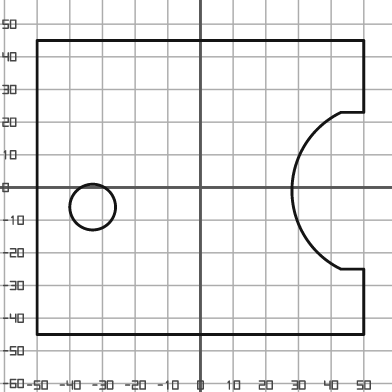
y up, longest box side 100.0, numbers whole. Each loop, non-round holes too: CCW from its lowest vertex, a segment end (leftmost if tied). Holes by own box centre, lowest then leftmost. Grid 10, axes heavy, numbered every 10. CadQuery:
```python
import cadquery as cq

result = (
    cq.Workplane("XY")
    .moveTo(-50.0, -45.0)
    .lineTo(50.0, -45.0)
    .lineTo(50.0, -25.0)
    .lineTo(43.0, -25.0)
    .threePointArc((28.0, -1.0), (43.0, 23.0))
    .lineTo(50.0, 23.0)
    .lineTo(50.0, 45.0)
    .lineTo(-50.0, 45.0)
    .close()
    .moveTo(-33.0, -6.0)
    .circle(7.0)
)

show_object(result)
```